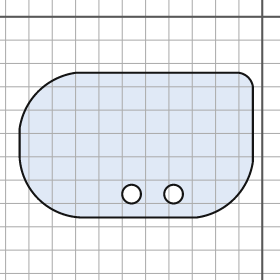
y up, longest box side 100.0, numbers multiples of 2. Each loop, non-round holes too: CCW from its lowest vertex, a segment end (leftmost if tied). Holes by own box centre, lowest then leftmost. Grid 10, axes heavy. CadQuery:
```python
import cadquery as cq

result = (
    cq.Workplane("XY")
    .moveTo(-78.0, -86.0)
    .lineTo(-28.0, -86.0)
    .threePointArc((-12.0, -78.0), (-4.0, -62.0))
    .lineTo(-4.0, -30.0)
    .threePointArc((-6.0, -26.0), (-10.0, -24.0))
    .lineTo(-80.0, -24.0)
    .threePointArc((-96.0, -32.0), (-104.0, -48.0))
    .lineTo(-104.0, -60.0)
    .threePointArc((-96.0, -78.0), (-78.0, -86.0))
    .close()
    .moveTo(-56.0, -76.0)
    .circle(4.0)
    .moveTo(-38.0, -76.0)
    .circle(4.0)
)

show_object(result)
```